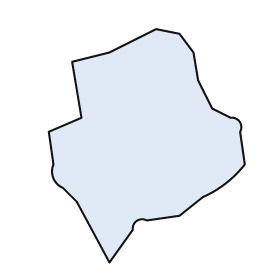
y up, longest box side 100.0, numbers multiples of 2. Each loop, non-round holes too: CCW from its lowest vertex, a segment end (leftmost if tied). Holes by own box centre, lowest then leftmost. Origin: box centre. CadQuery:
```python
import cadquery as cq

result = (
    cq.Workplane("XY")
    .moveTo(-16.0, -50.0)
    .lineTo(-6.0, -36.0)
    .threePointArc((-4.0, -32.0), (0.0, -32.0))
    .lineTo(14.0, -30.0)
    .lineTo(24.0, -22.0)
    .threePointArc((34.0, -16.0), (42.0, -8.0))
    .lineTo(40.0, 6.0)
    .threePointArc((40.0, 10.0), (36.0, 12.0))
    .lineTo(28.0, 16.0)
    .lineTo(22.0, 28.0)
    .lineTo(20.0, 40.0)
    .lineTo(14.0, 48.0)
    .lineTo(4.0, 50.0)
    .lineTo(-16.0, 40.0)
    .lineTo(-32.0, 36.0)
    .lineTo(-28.0, 12.0)
    .lineTo(-42.0, 6.0)
    .lineTo(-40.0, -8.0)
    .threePointArc((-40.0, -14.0), (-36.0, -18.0))
    .lineTo(-30.0, -24.0)
    .close()
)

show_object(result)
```